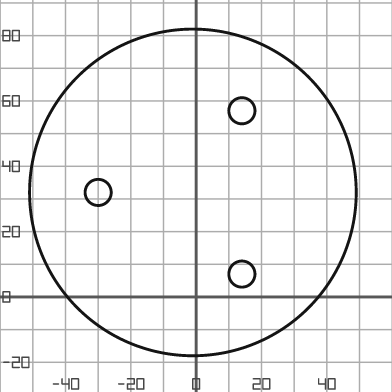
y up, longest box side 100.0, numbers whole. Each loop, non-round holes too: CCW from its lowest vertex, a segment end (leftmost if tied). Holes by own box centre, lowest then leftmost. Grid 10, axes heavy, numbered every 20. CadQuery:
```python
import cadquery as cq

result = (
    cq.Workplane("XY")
    .moveTo(-1.0, 32.0)
    .circle(50.0)
    .moveTo(14.0, 7.0)
    .circle(4.0)
    .moveTo(-30.0, 32.0)
    .circle(4.0)
    .moveTo(14.0, 57.0)
    .circle(4.0)
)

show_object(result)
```